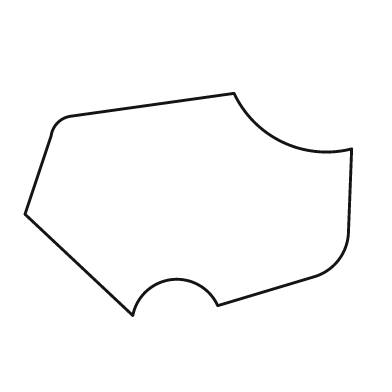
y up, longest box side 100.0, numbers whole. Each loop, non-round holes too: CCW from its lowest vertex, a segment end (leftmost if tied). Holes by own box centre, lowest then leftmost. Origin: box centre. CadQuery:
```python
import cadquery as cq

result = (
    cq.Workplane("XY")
    .moveTo(-17.0, -34.0)
    .threePointArc((-5.0, -23.0), (9.0, -31.0))
    .lineTo(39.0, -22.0)
    .threePointArc((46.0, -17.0), (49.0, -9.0))
    .lineTo(50.0, 17.0)
    .threePointArc((29.0, 19.0), (14.0, 34.0))
    .lineTo(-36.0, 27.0)
    .threePointArc((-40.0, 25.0), (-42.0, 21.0))
    .lineTo(-50.0, -3.0)
    .close()
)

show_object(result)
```